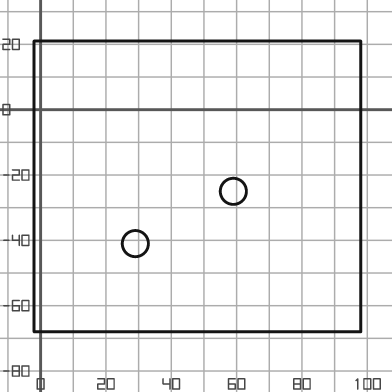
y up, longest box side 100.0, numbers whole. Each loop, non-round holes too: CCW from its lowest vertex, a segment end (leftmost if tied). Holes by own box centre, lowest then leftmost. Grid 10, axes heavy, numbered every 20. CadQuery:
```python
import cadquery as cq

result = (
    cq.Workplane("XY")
    .moveTo(-2.0, -68.0)
    .lineTo(98.0, -68.0)
    .lineTo(98.0, 21.0)
    .lineTo(-2.0, 21.0)
    .close()
    .moveTo(29.0, -41.0)
    .circle(4.0)
    .moveTo(59.0, -25.0)
    .circle(4.0)
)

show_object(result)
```